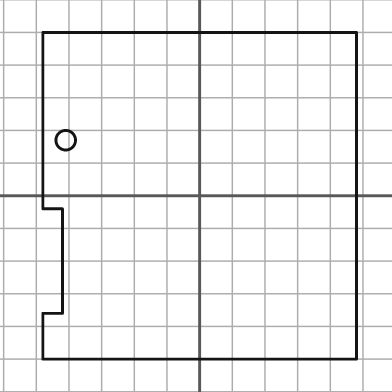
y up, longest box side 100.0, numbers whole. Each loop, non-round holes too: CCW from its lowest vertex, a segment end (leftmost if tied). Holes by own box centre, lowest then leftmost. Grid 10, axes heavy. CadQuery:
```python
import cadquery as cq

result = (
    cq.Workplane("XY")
    .moveTo(-48.0, -50.0)
    .lineTo(48.0, -50.0)
    .lineTo(48.0, 50.0)
    .lineTo(-48.0, 50.0)
    .lineTo(-48.0, -4.0)
    .lineTo(-42.0, -4.0)
    .lineTo(-42.0, -36.0)
    .lineTo(-48.0, -36.0)
    .close()
    .moveTo(-41.0, 17.0)
    .circle(3.0)
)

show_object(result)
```